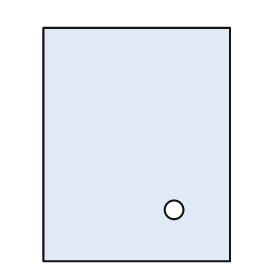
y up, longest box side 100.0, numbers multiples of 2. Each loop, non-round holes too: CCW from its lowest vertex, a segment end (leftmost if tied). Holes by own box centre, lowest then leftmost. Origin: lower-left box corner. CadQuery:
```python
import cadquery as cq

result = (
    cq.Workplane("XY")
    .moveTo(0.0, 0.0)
    .lineTo(80.0, 0.0)
    .lineTo(80.0, 100.0)
    .lineTo(0.0, 100.0)
    .close()
    .moveTo(56.0, 22.0)
    .circle(4.0)
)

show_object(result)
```